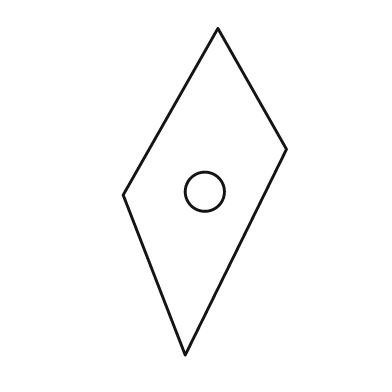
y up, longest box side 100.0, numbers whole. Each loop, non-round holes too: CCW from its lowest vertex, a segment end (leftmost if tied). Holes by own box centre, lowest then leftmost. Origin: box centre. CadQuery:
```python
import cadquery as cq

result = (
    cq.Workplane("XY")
    .moveTo(-6.0, -50.0)
    .lineTo(25.0, 13.0)
    .lineTo(4.0, 50.0)
    .lineTo(-25.0, -1.0)
    .close()
    .moveTo(0.0, 0.0)
    .circle(6.0)
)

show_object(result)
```